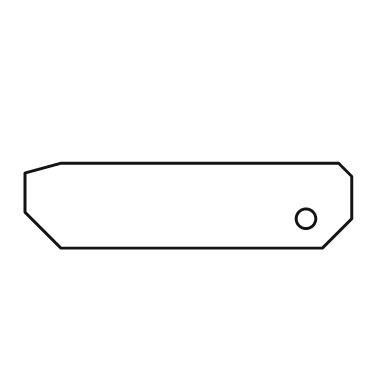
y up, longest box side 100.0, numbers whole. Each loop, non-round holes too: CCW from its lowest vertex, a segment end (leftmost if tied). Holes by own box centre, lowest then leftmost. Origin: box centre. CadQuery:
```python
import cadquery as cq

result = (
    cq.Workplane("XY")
    .moveTo(-39.0, -13.0)
    .lineTo(41.0, -13.0)
    .lineTo(50.0, -4.0)
    .lineTo(50.0, 9.0)
    .lineTo(46.0, 13.0)
    .lineTo(-39.0, 13.0)
    .lineTo(-50.0, 10.0)
    .lineTo(-50.0, -2.0)
    .close()
    .moveTo(36.0, -4.0)
    .circle(3.0)
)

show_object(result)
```